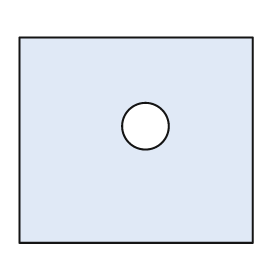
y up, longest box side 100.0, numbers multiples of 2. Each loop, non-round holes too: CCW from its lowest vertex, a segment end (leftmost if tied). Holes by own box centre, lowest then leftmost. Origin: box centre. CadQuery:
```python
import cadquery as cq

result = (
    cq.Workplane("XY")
    .moveTo(-50.0, -44.0)
    .lineTo(50.0, -44.0)
    .lineTo(50.0, 44.0)
    .lineTo(-50.0, 44.0)
    .close()
    .moveTo(4.0, 6.0)
    .circle(10.0)
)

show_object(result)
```